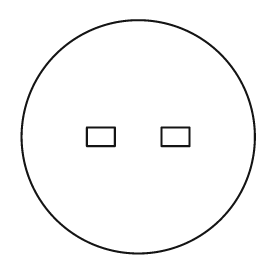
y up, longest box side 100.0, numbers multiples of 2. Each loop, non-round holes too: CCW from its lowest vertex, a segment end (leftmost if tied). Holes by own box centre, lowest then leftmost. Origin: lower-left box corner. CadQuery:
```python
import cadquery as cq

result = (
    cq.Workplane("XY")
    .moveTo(50.0, 50.0)
    .circle(50.0)
    .moveTo(28.0, 46.0)
    .lineTo(40.0, 46.0)
    .lineTo(40.0, 54.0)
    .lineTo(28.0, 54.0)
    .close()
    .moveTo(60.0, 46.0)
    .lineTo(72.0, 46.0)
    .lineTo(72.0, 54.0)
    .lineTo(60.0, 54.0)
    .close()
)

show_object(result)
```